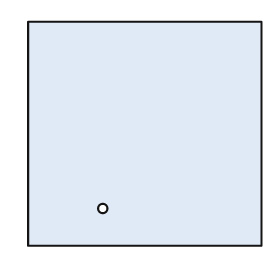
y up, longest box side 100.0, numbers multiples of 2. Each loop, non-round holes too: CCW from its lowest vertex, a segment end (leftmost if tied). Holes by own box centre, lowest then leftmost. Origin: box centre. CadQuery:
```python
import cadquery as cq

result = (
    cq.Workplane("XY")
    .moveTo(-50.0, -48.0)
    .lineTo(50.0, -48.0)
    .lineTo(50.0, 48.0)
    .lineTo(-50.0, 48.0)
    .close()
    .moveTo(-18.0, -32.0)
    .circle(2.0)
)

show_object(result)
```